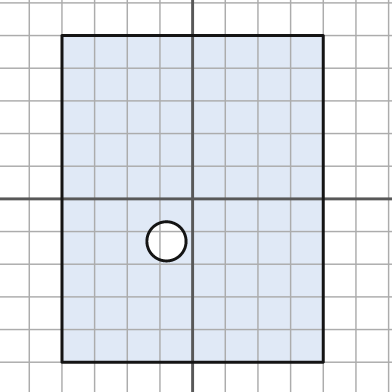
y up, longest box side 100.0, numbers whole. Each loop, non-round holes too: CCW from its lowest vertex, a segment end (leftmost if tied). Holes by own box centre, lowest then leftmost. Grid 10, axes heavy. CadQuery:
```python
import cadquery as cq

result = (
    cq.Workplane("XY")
    .moveTo(-40.0, -50.0)
    .lineTo(40.0, -50.0)
    .lineTo(40.0, 50.0)
    .lineTo(-40.0, 50.0)
    .close()
    .moveTo(-8.0, -13.0)
    .circle(6.0)
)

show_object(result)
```